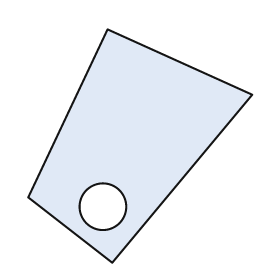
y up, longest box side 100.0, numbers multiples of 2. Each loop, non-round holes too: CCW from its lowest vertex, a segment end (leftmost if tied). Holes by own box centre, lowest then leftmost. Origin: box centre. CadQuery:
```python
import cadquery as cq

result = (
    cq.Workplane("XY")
    .moveTo(-12.0, -50.0)
    .lineTo(48.0, 22.0)
    .lineTo(-14.0, 50.0)
    .lineTo(-48.0, -22.0)
    .close()
    .moveTo(-16.0, -26.0)
    .circle(10.0)
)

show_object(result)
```